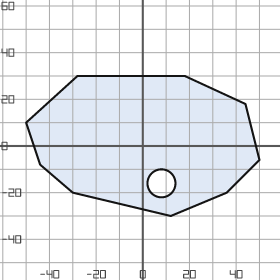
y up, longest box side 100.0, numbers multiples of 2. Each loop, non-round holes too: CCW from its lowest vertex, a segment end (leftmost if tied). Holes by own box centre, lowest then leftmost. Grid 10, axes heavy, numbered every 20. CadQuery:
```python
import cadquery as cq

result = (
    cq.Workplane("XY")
    .moveTo(12.0, -30.0)
    .lineTo(36.0, -20.0)
    .lineTo(50.0, -6.0)
    .lineTo(44.0, 18.0)
    .lineTo(18.0, 30.0)
    .lineTo(-28.0, 30.0)
    .lineTo(-50.0, 10.0)
    .lineTo(-44.0, -8.0)
    .lineTo(-30.0, -20.0)
    .close()
    .moveTo(8.0, -16.0)
    .circle(6.0)
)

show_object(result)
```